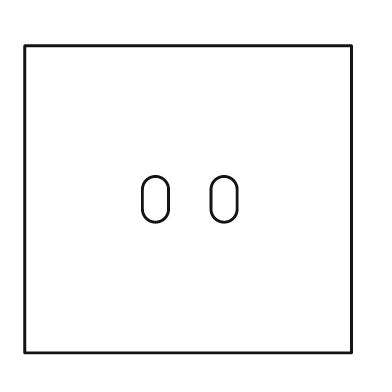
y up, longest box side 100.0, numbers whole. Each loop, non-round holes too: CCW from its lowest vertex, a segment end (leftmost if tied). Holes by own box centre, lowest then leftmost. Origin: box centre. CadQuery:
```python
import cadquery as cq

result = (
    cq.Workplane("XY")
    .moveTo(-50.0, -47.0)
    .lineTo(50.0, -47.0)
    .lineTo(50.0, 47.0)
    .lineTo(-50.0, 47.0)
    .close()
    .moveTo(-14.0, -3.0)
    .threePointArc((-10.0, -7.0), (-6.0, -3.0))
    .lineTo(-6.0, 3.0)
    .threePointArc((-10.0, 7.0), (-14.0, 3.0))
    .close()
    .moveTo(7.0, -3.0)
    .threePointArc((11.0, -7.0), (15.0, -3.0))
    .lineTo(15.0, 3.0)
    .threePointArc((11.0, 7.0), (7.0, 3.0))
    .close()
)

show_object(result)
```